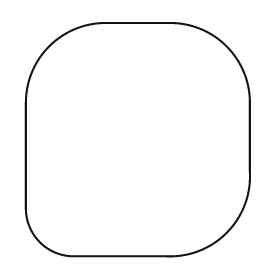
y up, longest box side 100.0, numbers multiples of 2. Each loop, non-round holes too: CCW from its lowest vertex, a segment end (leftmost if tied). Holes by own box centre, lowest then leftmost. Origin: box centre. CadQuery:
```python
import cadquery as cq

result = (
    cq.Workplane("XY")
    .moveTo(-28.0, -50.0)
    .lineTo(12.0, -50.0)
    .threePointArc((38.0, -40.0), (48.0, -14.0))
    .lineTo(48.0, 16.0)
    .threePointArc((38.0, 40.0), (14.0, 50.0))
    .lineTo(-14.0, 50.0)
    .threePointArc((-38.0, 40.0), (-48.0, 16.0))
    .lineTo(-48.0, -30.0)
    .threePointArc((-42.0, -44.0), (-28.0, -50.0))
    .close()
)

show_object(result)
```